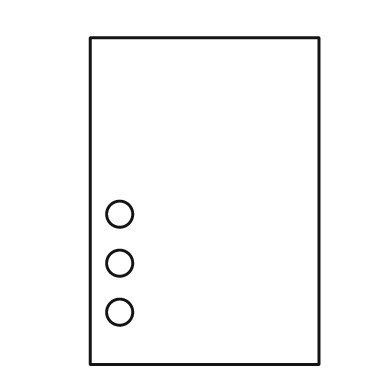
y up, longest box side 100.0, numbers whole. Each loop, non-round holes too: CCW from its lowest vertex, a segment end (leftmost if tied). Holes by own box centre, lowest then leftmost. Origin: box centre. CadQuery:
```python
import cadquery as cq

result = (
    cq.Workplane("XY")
    .moveTo(-35.0, -50.0)
    .lineTo(35.0, -50.0)
    .lineTo(35.0, 50.0)
    .lineTo(-35.0, 50.0)
    .close()
    .moveTo(-26.0, -34.0)
    .circle(4.0)
    .moveTo(-26.0, -19.0)
    .circle(4.0)
    .moveTo(-26.0, -4.0)
    .circle(4.0)
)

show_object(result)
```